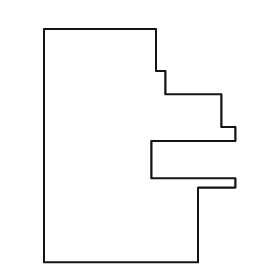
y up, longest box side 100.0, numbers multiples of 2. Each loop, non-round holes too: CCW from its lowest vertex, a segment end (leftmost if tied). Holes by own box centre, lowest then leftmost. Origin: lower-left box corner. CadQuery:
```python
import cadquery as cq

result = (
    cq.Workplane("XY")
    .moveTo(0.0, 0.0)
    .lineTo(66.0, 0.0)
    .lineTo(66.0, 32.0)
    .lineTo(82.0, 32.0)
    .lineTo(82.0, 36.0)
    .lineTo(46.0, 36.0)
    .lineTo(46.0, 52.0)
    .lineTo(82.0, 52.0)
    .lineTo(82.0, 58.0)
    .lineTo(76.0, 58.0)
    .lineTo(76.0, 72.0)
    .lineTo(52.0, 72.0)
    .lineTo(52.0, 82.0)
    .lineTo(48.0, 82.0)
    .lineTo(48.0, 100.0)
    .lineTo(0.0, 100.0)
    .close()
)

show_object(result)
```